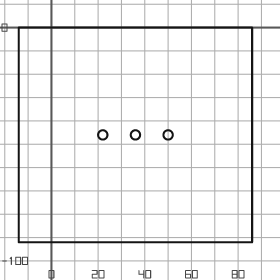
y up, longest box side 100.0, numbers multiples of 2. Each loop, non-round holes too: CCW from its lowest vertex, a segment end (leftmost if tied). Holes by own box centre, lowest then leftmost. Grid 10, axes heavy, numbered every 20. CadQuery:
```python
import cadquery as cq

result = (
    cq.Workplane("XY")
    .moveTo(-14.0, -92.0)
    .lineTo(86.0, -92.0)
    .lineTo(86.0, 0.0)
    .lineTo(-14.0, 0.0)
    .close()
    .moveTo(22.0, -46.0)
    .circle(2.0)
    .moveTo(36.0, -46.0)
    .circle(2.0)
    .moveTo(50.0, -46.0)
    .circle(2.0)
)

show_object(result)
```